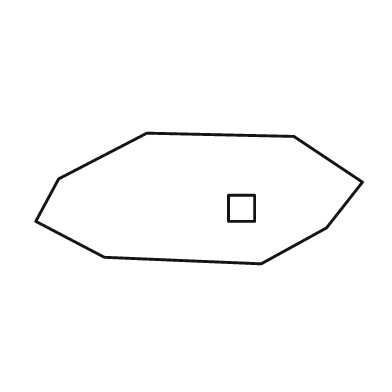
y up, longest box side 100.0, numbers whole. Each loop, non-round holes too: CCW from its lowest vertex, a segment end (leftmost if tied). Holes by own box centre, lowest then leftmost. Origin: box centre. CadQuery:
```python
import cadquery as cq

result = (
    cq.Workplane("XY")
    .moveTo(19.0, -20.0)
    .lineTo(39.0, -9.0)
    .lineTo(50.0, 5.0)
    .lineTo(29.0, 19.0)
    .lineTo(-16.0, 20.0)
    .lineTo(-43.0, 6.0)
    .lineTo(-50.0, -7.0)
    .lineTo(-29.0, -18.0)
    .close()
    .moveTo(9.0, -7.0)
    .lineTo(17.0, -7.0)
    .lineTo(17.0, 1.0)
    .lineTo(9.0, 1.0)
    .close()
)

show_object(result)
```